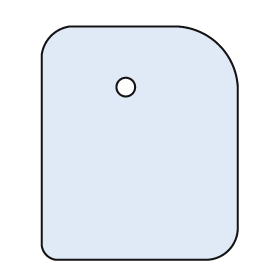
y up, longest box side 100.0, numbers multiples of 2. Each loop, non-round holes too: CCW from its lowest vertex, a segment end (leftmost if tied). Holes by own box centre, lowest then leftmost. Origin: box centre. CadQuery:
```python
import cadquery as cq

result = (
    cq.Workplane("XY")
    .moveTo(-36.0, -50.0)
    .lineTo(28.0, -50.0)
    .threePointArc((38.0, -46.0), (42.0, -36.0))
    .lineTo(42.0, 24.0)
    .threePointArc((34.0, 42.0), (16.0, 50.0))
    .lineTo(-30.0, 50.0)
    .threePointArc((-38.0, 46.0), (-42.0, 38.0))
    .lineTo(-42.0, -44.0)
    .threePointArc((-40.0, -48.0), (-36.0, -50.0))
    .close()
    .moveTo(-6.0, 24.0)
    .circle(4.0)
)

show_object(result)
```